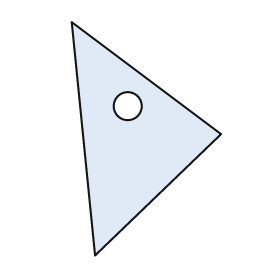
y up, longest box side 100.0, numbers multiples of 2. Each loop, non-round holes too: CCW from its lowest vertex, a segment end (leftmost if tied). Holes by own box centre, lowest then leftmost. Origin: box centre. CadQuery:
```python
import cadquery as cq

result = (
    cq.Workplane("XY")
    .moveTo(-22.0, -50.0)
    .lineTo(32.0, 2.0)
    .lineTo(-32.0, 50.0)
    .close()
    .moveTo(-8.0, 14.0)
    .circle(6.0)
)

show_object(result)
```